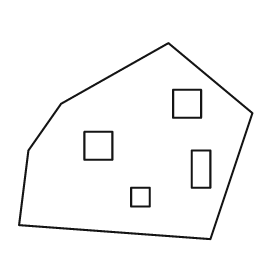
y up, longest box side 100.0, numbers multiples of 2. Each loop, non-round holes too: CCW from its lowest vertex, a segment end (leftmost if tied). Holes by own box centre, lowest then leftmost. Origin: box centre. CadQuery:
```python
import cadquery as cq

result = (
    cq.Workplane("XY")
    .moveTo(32.0, -42.0)
    .lineTo(50.0, 12.0)
    .lineTo(14.0, 42.0)
    .lineTo(-32.0, 16.0)
    .lineTo(-46.0, -4.0)
    .lineTo(-50.0, -36.0)
    .close()
    .moveTo(-2.0, -28.0)
    .lineTo(6.0, -28.0)
    .lineTo(6.0, -20.0)
    .lineTo(-2.0, -20.0)
    .close()
    .moveTo(24.0, -20.0)
    .lineTo(32.0, -20.0)
    .lineTo(32.0, -4.0)
    .lineTo(24.0, -4.0)
    .close()
    .moveTo(-22.0, -8.0)
    .lineTo(-10.0, -8.0)
    .lineTo(-10.0, 4.0)
    .lineTo(-22.0, 4.0)
    .close()
    .moveTo(16.0, 10.0)
    .lineTo(28.0, 10.0)
    .lineTo(28.0, 22.0)
    .lineTo(16.0, 22.0)
    .close()
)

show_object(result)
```